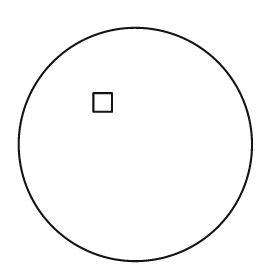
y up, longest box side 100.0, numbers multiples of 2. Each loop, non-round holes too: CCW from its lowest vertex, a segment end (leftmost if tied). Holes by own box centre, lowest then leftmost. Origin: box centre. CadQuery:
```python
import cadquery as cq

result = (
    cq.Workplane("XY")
    .moveTo(0.0, 0.0)
    .circle(50.0)
    .moveTo(-18.0, 14.0)
    .lineTo(-10.0, 14.0)
    .lineTo(-10.0, 22.0)
    .lineTo(-18.0, 22.0)
    .close()
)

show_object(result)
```